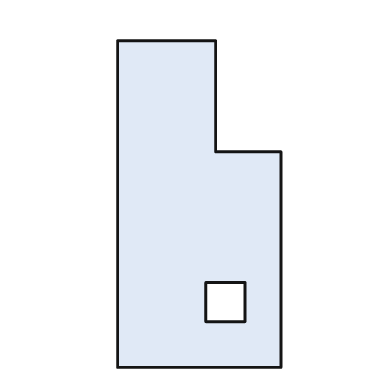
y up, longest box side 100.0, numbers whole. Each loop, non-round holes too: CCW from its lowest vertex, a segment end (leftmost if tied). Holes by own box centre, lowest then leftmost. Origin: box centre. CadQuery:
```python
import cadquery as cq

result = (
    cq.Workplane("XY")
    .moveTo(-25.0, -50.0)
    .lineTo(25.0, -50.0)
    .lineTo(25.0, 16.0)
    .lineTo(5.0, 16.0)
    .lineTo(5.0, 50.0)
    .lineTo(-25.0, 50.0)
    .close()
    .moveTo(2.0, -36.0)
    .lineTo(14.0, -36.0)
    .lineTo(14.0, -24.0)
    .lineTo(2.0, -24.0)
    .close()
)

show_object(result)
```